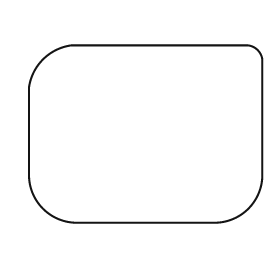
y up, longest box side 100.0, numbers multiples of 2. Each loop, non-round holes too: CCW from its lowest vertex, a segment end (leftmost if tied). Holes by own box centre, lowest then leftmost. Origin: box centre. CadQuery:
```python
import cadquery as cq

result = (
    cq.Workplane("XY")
    .moveTo(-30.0, -38.0)
    .lineTo(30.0, -38.0)
    .threePointArc((44.0, -32.0), (50.0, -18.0))
    .lineTo(50.0, 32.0)
    .threePointArc((48.0, 36.0), (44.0, 38.0))
    .lineTo(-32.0, 38.0)
    .threePointArc((-44.0, 32.0), (-50.0, 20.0))
    .lineTo(-50.0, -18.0)
    .threePointArc((-44.0, -32.0), (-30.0, -38.0))
    .close()
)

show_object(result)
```